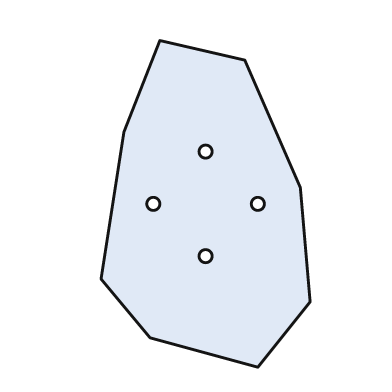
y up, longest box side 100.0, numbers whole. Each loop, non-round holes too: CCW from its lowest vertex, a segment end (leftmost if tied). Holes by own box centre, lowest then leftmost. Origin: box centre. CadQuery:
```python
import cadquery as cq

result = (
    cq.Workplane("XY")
    .moveTo(16.0, -50.0)
    .lineTo(32.0, -30.0)
    .lineTo(29.0, 5.0)
    .lineTo(12.0, 44.0)
    .lineTo(-14.0, 50.0)
    .lineTo(-25.0, 22.0)
    .lineTo(-32.0, -23.0)
    .lineTo(-17.0, -41.0)
    .close()
    .moveTo(0.0, -16.0)
    .circle(2.0)
    .moveTo(-16.0, 0.0)
    .circle(2.0)
    .moveTo(16.0, 0.0)
    .circle(2.0)
    .moveTo(0.0, 16.0)
    .circle(2.0)
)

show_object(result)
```